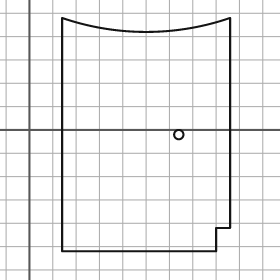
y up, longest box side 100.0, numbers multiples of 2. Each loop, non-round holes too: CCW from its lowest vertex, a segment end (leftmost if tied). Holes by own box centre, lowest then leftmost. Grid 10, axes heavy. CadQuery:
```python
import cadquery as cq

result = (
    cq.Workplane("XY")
    .moveTo(14.0, -52.0)
    .lineTo(80.0, -52.0)
    .lineTo(80.0, -42.0)
    .lineTo(86.0, -42.0)
    .lineTo(86.0, 48.0)
    .threePointArc((50.0, 42.0), (14.0, 48.0))
    .close()
    .moveTo(64.0, -2.0)
    .circle(2.0)
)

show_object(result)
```